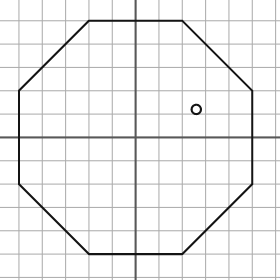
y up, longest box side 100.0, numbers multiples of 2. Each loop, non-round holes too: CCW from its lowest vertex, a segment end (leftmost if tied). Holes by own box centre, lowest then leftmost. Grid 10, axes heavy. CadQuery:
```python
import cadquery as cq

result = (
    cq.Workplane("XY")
    .moveTo(-20.0, -50.0)
    .lineTo(20.0, -50.0)
    .lineTo(50.0, -20.0)
    .lineTo(50.0, 20.0)
    .lineTo(20.0, 50.0)
    .lineTo(-20.0, 50.0)
    .lineTo(-50.0, 20.0)
    .lineTo(-50.0, -20.0)
    .close()
    .moveTo(26.0, 12.0)
    .circle(2.0)
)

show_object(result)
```